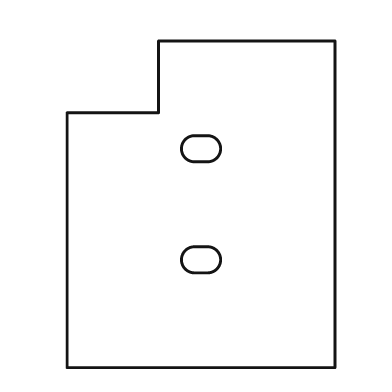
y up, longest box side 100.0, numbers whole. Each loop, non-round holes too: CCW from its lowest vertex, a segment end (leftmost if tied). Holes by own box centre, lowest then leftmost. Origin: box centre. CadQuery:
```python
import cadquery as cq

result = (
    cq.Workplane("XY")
    .moveTo(-41.0, -50.0)
    .lineTo(41.0, -50.0)
    .lineTo(41.0, 50.0)
    .lineTo(-13.0, 50.0)
    .lineTo(-13.0, 28.0)
    .lineTo(-41.0, 28.0)
    .close()
    .moveTo(-2.0, -21.0)
    .lineTo(2.0, -21.0)
    .threePointArc((6.0, -17.0), (2.0, -13.0))
    .lineTo(-2.0, -13.0)
    .threePointArc((-6.0, -17.0), (-2.0, -21.0))
    .close()
    .moveTo(-2.0, 13.0)
    .lineTo(2.0, 13.0)
    .threePointArc((6.0, 17.0), (2.0, 21.0))
    .lineTo(-2.0, 21.0)
    .threePointArc((-6.0, 17.0), (-2.0, 13.0))
    .close()
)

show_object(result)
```